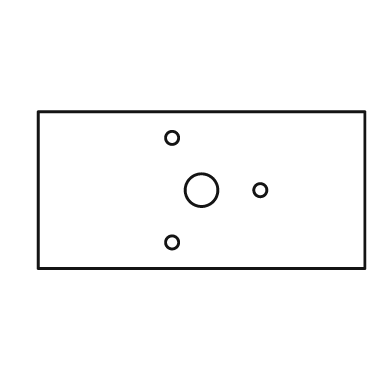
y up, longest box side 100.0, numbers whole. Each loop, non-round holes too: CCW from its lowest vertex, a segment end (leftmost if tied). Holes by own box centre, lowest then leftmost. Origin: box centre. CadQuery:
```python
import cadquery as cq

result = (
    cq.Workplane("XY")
    .moveTo(-50.0, -24.0)
    .lineTo(50.0, -24.0)
    .lineTo(50.0, 24.0)
    .lineTo(-50.0, 24.0)
    .close()
    .moveTo(-9.0, -16.0)
    .circle(2.0)
    .moveTo(0.0, 0.0)
    .circle(5.0)
    .moveTo(18.0, 0.0)
    .circle(2.0)
    .moveTo(-9.0, 16.0)
    .circle(2.0)
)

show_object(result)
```